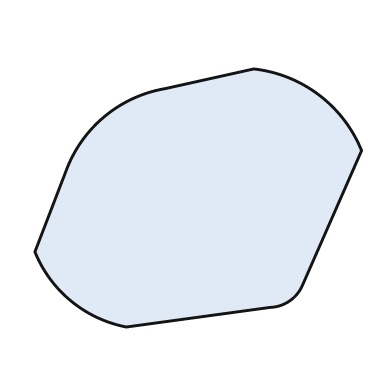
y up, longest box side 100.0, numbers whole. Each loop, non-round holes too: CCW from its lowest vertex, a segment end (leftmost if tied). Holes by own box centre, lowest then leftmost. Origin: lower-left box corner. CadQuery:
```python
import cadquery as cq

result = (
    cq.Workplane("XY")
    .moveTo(28.0, 0.0)
    .lineTo(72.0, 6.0)
    .threePointArc((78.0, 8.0), (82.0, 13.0))
    .lineTo(100.0, 54.0)
    .threePointArc((87.0, 71.0), (67.0, 79.0))
    .lineTo(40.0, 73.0)
    .threePointArc((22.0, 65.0), (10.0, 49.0))
    .lineTo(0.0, 23.0)
    .threePointArc((11.0, 8.0), (28.0, 0.0))
    .close()
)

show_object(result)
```